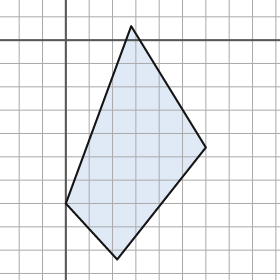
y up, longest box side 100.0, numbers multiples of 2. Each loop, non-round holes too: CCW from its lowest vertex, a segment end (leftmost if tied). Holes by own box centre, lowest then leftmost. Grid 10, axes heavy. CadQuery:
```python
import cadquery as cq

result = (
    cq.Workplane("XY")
    .moveTo(22.0, -94.0)
    .lineTo(60.0, -46.0)
    .lineTo(28.0, 6.0)
    .lineTo(0.0, -70.0)
    .close()
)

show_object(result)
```